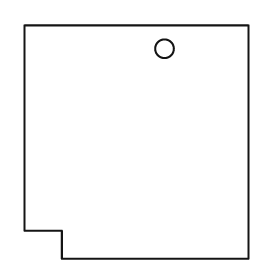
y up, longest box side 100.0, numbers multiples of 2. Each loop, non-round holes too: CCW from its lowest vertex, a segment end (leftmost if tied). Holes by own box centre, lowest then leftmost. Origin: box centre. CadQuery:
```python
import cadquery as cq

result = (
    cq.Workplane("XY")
    .moveTo(-32.0, -50.0)
    .lineTo(48.0, -50.0)
    .lineTo(48.0, 50.0)
    .lineTo(-48.0, 50.0)
    .lineTo(-48.0, -38.0)
    .lineTo(-32.0, -38.0)
    .close()
    .moveTo(12.0, 40.0)
    .circle(4.0)
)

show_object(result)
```